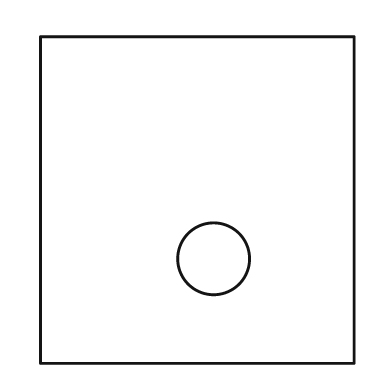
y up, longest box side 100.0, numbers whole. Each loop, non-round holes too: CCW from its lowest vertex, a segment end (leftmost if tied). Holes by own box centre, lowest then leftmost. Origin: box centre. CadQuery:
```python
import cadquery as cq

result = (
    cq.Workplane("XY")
    .moveTo(-48.0, -50.0)
    .lineTo(48.0, -50.0)
    .lineTo(48.0, 50.0)
    .lineTo(-48.0, 50.0)
    .close()
    .moveTo(5.0, -18.0)
    .circle(11.0)
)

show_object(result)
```